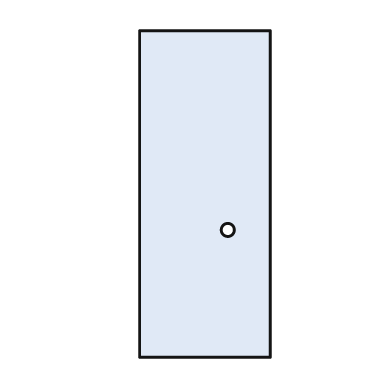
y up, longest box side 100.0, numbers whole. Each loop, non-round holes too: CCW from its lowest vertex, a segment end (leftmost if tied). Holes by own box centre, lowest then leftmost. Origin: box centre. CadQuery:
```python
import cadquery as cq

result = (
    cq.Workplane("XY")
    .moveTo(-20.0, -50.0)
    .lineTo(20.0, -50.0)
    .lineTo(20.0, 50.0)
    .lineTo(-20.0, 50.0)
    .close()
    .moveTo(7.0, -11.0)
    .circle(2.0)
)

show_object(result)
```